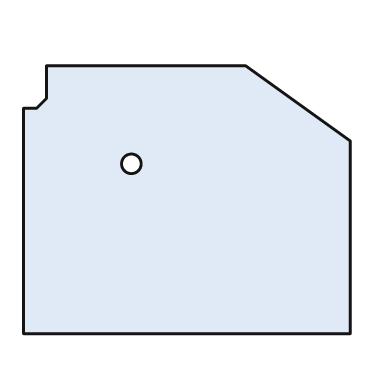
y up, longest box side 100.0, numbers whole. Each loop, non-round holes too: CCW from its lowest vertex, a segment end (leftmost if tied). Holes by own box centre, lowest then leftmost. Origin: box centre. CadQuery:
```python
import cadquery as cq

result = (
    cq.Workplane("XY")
    .moveTo(-50.0, -41.0)
    .lineTo(50.0, -41.0)
    .lineTo(50.0, 18.0)
    .lineTo(18.0, 41.0)
    .lineTo(-43.0, 41.0)
    .lineTo(-43.0, 31.0)
    .lineTo(-46.0, 28.0)
    .lineTo(-50.0, 28.0)
    .close()
    .moveTo(-17.0, 11.0)
    .circle(3.0)
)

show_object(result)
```